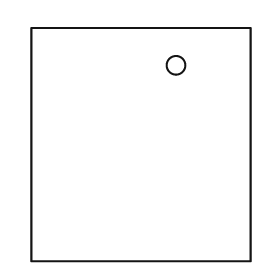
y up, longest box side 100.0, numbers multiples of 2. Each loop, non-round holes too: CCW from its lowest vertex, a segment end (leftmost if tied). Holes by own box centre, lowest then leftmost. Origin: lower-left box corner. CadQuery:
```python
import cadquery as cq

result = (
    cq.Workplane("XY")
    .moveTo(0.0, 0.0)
    .lineTo(94.0, 0.0)
    .lineTo(94.0, 100.0)
    .lineTo(0.0, 100.0)
    .close()
    .moveTo(62.0, 84.0)
    .circle(4.0)
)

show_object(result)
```